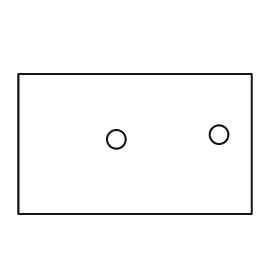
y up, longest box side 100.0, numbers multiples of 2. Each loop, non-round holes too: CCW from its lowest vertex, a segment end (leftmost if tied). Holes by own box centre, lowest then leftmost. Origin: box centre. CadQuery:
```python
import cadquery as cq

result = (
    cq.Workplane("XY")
    .moveTo(-50.0, -30.0)
    .lineTo(50.0, -30.0)
    .lineTo(50.0, 30.0)
    .lineTo(-50.0, 30.0)
    .close()
    .moveTo(-8.0, 2.0)
    .circle(4.0)
    .moveTo(36.0, 4.0)
    .circle(4.0)
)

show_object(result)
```